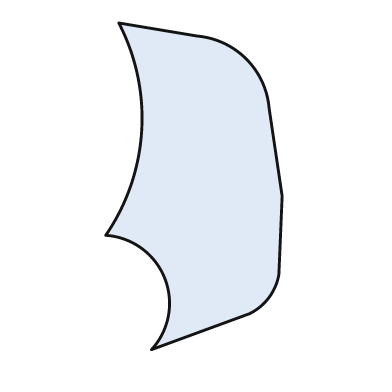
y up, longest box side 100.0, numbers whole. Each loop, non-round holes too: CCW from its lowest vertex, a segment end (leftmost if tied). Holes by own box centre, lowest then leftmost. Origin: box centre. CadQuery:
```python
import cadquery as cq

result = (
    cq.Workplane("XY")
    .moveTo(-13.0, -50.0)
    .lineTo(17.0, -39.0)
    .threePointArc((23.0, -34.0), (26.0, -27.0))
    .lineTo(27.0, -3.0)
    .lineTo(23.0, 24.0)
    .threePointArc((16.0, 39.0), (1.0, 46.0))
    .lineTo(-23.0, 50.0)
    .threePointArc((-16.0, 17.0), (-27.0, -15.0))
    .threePointArc((-9.0, -28.0), (-13.0, -50.0))
    .close()
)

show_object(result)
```